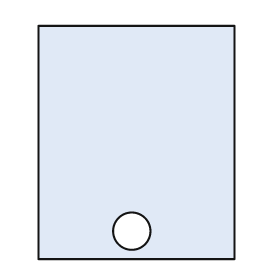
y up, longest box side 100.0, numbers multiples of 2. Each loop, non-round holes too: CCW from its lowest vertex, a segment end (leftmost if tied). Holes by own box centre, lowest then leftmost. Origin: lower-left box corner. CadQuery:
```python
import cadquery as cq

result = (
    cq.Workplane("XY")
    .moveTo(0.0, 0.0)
    .lineTo(84.0, 0.0)
    .lineTo(84.0, 100.0)
    .lineTo(0.0, 100.0)
    .close()
    .moveTo(40.0, 12.0)
    .circle(8.0)
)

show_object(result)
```